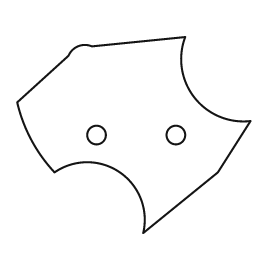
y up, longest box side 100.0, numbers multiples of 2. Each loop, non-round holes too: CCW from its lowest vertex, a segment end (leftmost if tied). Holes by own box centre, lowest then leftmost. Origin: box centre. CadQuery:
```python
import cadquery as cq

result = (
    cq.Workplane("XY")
    .moveTo(4.0, -42.0)
    .lineTo(36.0, -16.0)
    .lineTo(50.0, 6.0)
    .threePointArc((26.0, 16.0), (22.0, 42.0))
    .lineTo(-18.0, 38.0)
    .threePointArc((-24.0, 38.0), (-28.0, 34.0))
    .lineTo(-50.0, 14.0)
    .threePointArc((-44.0, -2.0), (-34.0, -16.0))
    .threePointArc((-6.0, -16.0), (4.0, -42.0))
    .close()
    .moveTo(-16.0, 0.0)
    .circle(4.0)
    .moveTo(18.0, 0.0)
    .circle(4.0)
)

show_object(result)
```